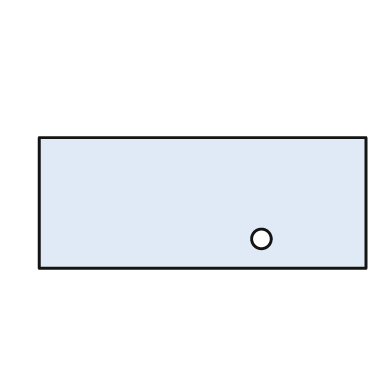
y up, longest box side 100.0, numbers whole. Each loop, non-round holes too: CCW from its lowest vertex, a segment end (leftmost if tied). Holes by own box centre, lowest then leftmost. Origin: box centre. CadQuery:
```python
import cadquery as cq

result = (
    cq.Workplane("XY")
    .moveTo(-50.0, -20.0)
    .lineTo(50.0, -20.0)
    .lineTo(50.0, 20.0)
    .lineTo(-50.0, 20.0)
    .close()
    .moveTo(18.0, -11.0)
    .circle(3.0)
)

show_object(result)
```